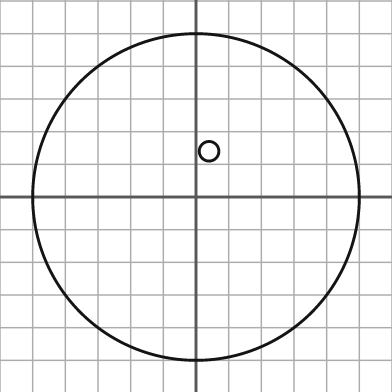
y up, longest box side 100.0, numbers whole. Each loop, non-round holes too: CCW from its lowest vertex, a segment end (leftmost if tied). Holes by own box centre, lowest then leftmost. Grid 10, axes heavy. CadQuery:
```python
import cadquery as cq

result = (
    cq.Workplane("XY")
    .moveTo(0.0, 0.0)
    .circle(50.0)
    .moveTo(4.0, 14.0)
    .circle(3.0)
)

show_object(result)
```